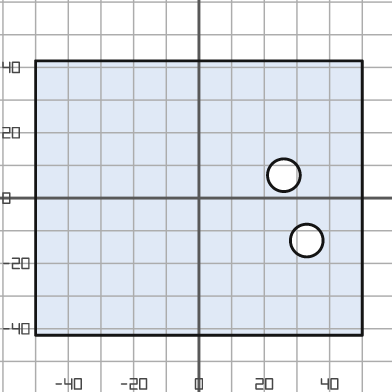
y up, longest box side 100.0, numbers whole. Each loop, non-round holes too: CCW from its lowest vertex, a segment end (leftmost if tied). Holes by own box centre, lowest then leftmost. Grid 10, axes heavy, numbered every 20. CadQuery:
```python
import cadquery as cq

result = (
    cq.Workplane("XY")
    .moveTo(-50.0, -42.0)
    .lineTo(50.0, -42.0)
    .lineTo(50.0, 42.0)
    .lineTo(-50.0, 42.0)
    .close()
    .moveTo(33.0, -13.0)
    .circle(5.0)
    .moveTo(26.0, 7.0)
    .circle(5.0)
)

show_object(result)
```